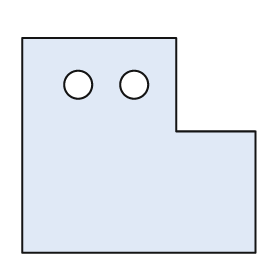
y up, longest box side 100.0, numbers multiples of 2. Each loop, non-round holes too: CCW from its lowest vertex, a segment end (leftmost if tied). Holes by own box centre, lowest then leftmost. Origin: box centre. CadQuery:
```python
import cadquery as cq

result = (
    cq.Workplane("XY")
    .moveTo(-50.0, -46.0)
    .lineTo(50.0, -46.0)
    .lineTo(50.0, 6.0)
    .lineTo(16.0, 6.0)
    .lineTo(16.0, 46.0)
    .lineTo(-50.0, 46.0)
    .close()
    .moveTo(-26.0, 26.0)
    .circle(6.0)
    .moveTo(-2.0, 26.0)
    .circle(6.0)
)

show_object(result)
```